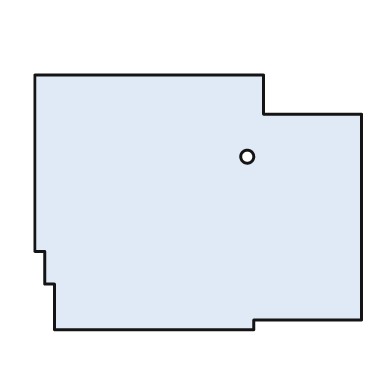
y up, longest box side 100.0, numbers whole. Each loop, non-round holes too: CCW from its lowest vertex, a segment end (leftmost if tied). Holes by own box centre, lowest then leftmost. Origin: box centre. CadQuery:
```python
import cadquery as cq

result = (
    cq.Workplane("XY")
    .moveTo(-44.0, -39.0)
    .lineTo(17.0, -39.0)
    .lineTo(17.0, -36.0)
    .lineTo(50.0, -36.0)
    .lineTo(50.0, 27.0)
    .lineTo(20.0, 27.0)
    .lineTo(20.0, 39.0)
    .lineTo(-50.0, 39.0)
    .lineTo(-50.0, -15.0)
    .lineTo(-47.0, -15.0)
    .lineTo(-47.0, -25.0)
    .lineTo(-44.0, -25.0)
    .close()
    .moveTo(15.0, 14.0)
    .circle(2.0)
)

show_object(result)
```